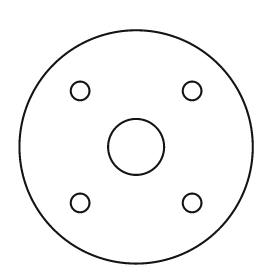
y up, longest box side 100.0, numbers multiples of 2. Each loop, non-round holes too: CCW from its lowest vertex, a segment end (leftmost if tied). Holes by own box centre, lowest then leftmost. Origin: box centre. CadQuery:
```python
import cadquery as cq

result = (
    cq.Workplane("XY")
    .moveTo(0.0, 0.0)
    .circle(50.0)
    .moveTo(-24.0, -24.0)
    .circle(4.0)
    .moveTo(24.0, -24.0)
    .circle(4.0)
    .moveTo(0.0, 0.0)
    .circle(12.0)
    .moveTo(-24.0, 24.0)
    .circle(4.0)
    .moveTo(24.0, 24.0)
    .circle(4.0)
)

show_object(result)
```